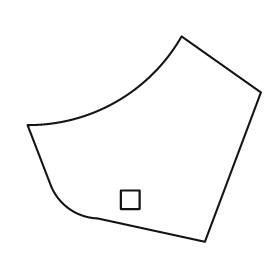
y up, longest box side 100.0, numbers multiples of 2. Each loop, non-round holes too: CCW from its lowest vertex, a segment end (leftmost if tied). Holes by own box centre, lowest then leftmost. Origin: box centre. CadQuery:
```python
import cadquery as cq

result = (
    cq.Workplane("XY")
    .moveTo(26.0, -44.0)
    .lineTo(50.0, 20.0)
    .lineTo(16.0, 44.0)
    .threePointArc((-12.0, 16.0), (-50.0, 6.0))
    .lineTo(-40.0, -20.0)
    .threePointArc((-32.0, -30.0), (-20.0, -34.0))
    .close()
    .moveTo(-10.0, -30.0)
    .lineTo(-2.0, -30.0)
    .lineTo(-2.0, -22.0)
    .lineTo(-10.0, -22.0)
    .close()
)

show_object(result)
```